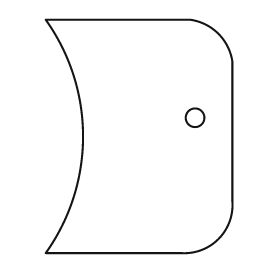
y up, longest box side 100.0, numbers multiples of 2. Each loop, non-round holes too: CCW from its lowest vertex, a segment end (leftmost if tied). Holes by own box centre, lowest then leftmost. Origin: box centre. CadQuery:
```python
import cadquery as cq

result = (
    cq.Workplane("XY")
    .moveTo(-40.0, -50.0)
    .lineTo(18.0, -50.0)
    .threePointArc((34.0, -44.0), (40.0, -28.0))
    .lineTo(40.0, 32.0)
    .threePointArc((34.0, 44.0), (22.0, 50.0))
    .lineTo(-40.0, 50.0)
    .threePointArc((-24.0, 0.0), (-40.0, -50.0))
    .close()
    .moveTo(24.0, 8.0)
    .circle(4.0)
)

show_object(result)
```